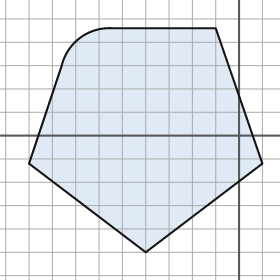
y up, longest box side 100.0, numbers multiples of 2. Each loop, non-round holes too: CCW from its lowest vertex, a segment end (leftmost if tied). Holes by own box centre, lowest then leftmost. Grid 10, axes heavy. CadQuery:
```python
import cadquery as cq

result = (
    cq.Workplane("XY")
    .moveTo(-40.0, -50.0)
    .lineTo(10.0, -12.0)
    .lineTo(-10.0, 46.0)
    .lineTo(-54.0, 46.0)
    .threePointArc((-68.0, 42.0), (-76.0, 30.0))
    .lineTo(-90.0, -12.0)
    .close()
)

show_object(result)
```